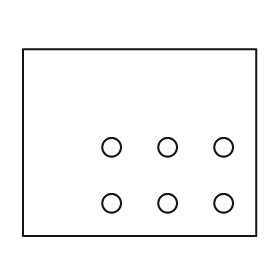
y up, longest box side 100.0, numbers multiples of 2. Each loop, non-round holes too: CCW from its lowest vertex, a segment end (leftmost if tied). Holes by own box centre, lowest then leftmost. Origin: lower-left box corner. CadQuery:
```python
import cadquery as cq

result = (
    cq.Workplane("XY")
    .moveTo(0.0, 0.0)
    .lineTo(100.0, 0.0)
    .lineTo(100.0, 80.0)
    .lineTo(0.0, 80.0)
    .close()
    .moveTo(38.0, 14.0)
    .circle(4.0)
    .moveTo(62.0, 14.0)
    .circle(4.0)
    .moveTo(86.0, 14.0)
    .circle(4.0)
    .moveTo(38.0, 38.0)
    .circle(4.0)
    .moveTo(62.0, 38.0)
    .circle(4.0)
    .moveTo(86.0, 38.0)
    .circle(4.0)
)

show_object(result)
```